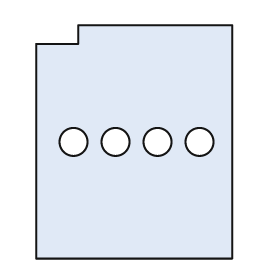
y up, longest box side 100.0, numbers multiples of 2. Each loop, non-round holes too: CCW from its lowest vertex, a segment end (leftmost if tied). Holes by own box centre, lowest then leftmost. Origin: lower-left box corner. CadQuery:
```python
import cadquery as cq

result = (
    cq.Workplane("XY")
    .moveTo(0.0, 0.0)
    .lineTo(84.0, 0.0)
    .lineTo(84.0, 100.0)
    .lineTo(18.0, 100.0)
    .lineTo(18.0, 92.0)
    .lineTo(0.0, 92.0)
    .close()
    .moveTo(16.0, 50.0)
    .circle(6.0)
    .moveTo(34.0, 50.0)
    .circle(6.0)
    .moveTo(52.0, 50.0)
    .circle(6.0)
    .moveTo(70.0, 50.0)
    .circle(6.0)
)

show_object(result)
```